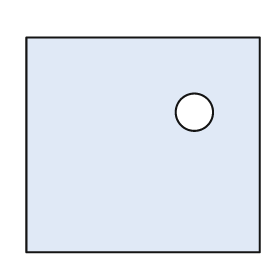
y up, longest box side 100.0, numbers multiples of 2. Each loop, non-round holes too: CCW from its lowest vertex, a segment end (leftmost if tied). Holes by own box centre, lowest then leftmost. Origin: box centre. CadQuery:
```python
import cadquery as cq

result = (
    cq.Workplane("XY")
    .moveTo(-50.0, -46.0)
    .lineTo(50.0, -46.0)
    .lineTo(50.0, 46.0)
    .lineTo(-50.0, 46.0)
    .close()
    .moveTo(22.0, 14.0)
    .circle(8.0)
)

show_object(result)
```